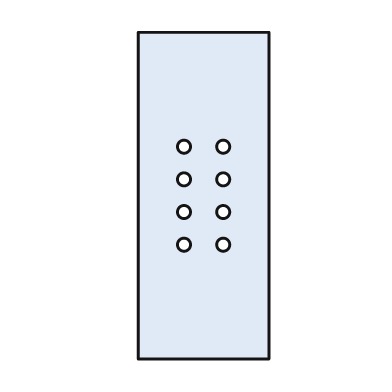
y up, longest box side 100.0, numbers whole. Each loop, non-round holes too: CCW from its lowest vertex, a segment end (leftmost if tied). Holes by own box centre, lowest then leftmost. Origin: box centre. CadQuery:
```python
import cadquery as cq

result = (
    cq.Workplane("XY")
    .moveTo(-20.0, -50.0)
    .lineTo(20.0, -50.0)
    .lineTo(20.0, 50.0)
    .lineTo(-20.0, 50.0)
    .close()
    .moveTo(-6.0, -15.0)
    .circle(2.0)
    .moveTo(6.0, -15.0)
    .circle(2.0)
    .moveTo(-6.0, -5.0)
    .circle(2.0)
    .moveTo(6.0, -5.0)
    .circle(2.0)
    .moveTo(-6.0, 5.0)
    .circle(2.0)
    .moveTo(6.0, 5.0)
    .circle(2.0)
    .moveTo(-6.0, 15.0)
    .circle(2.0)
    .moveTo(6.0, 15.0)
    .circle(2.0)
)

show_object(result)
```